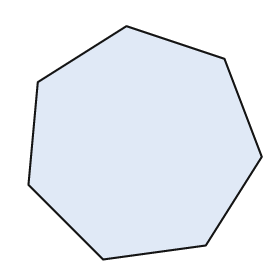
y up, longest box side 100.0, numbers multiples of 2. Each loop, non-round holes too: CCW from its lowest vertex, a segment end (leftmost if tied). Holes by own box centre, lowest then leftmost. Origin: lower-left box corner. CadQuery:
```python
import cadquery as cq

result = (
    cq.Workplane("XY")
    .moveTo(32.0, 0.0)
    .lineTo(76.0, 6.0)
    .lineTo(100.0, 44.0)
    .lineTo(84.0, 86.0)
    .lineTo(42.0, 100.0)
    .lineTo(4.0, 76.0)
    .lineTo(0.0, 32.0)
    .close()
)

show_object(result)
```